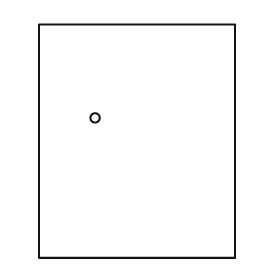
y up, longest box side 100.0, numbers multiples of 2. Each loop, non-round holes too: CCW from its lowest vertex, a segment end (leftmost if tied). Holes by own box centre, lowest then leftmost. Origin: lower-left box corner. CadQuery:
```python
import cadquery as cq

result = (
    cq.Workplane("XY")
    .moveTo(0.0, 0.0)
    .lineTo(84.0, 0.0)
    .lineTo(84.0, 100.0)
    .lineTo(0.0, 100.0)
    .close()
    .moveTo(24.0, 60.0)
    .circle(2.0)
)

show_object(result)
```